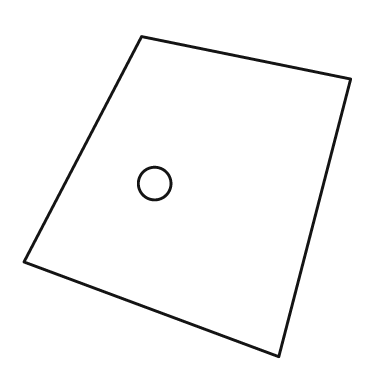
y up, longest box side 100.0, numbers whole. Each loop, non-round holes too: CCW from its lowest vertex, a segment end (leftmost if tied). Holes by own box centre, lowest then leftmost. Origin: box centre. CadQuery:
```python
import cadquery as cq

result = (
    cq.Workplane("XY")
    .moveTo(28.0, -49.0)
    .lineTo(50.0, 36.0)
    .lineTo(-14.0, 49.0)
    .lineTo(-50.0, -20.0)
    .close()
    .moveTo(-10.0, 4.0)
    .circle(5.0)
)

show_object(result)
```